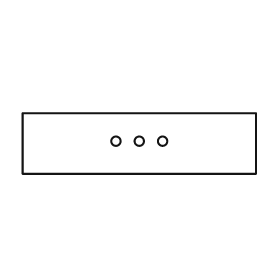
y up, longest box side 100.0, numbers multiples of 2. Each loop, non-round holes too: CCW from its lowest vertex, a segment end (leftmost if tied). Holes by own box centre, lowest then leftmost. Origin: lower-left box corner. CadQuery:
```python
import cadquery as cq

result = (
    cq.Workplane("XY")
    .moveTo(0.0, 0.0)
    .lineTo(100.0, 0.0)
    .lineTo(100.0, 26.0)
    .lineTo(0.0, 26.0)
    .close()
    .moveTo(40.0, 14.0)
    .circle(2.0)
    .moveTo(50.0, 14.0)
    .circle(2.0)
    .moveTo(60.0, 14.0)
    .circle(2.0)
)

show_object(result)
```